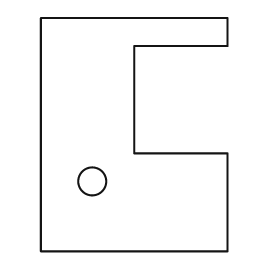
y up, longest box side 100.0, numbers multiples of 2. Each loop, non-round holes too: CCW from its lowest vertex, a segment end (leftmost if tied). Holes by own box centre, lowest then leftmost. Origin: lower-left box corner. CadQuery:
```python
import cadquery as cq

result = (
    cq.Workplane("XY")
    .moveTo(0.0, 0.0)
    .lineTo(80.0, 0.0)
    .lineTo(80.0, 42.0)
    .lineTo(40.0, 42.0)
    .lineTo(40.0, 88.0)
    .lineTo(80.0, 88.0)
    .lineTo(80.0, 100.0)
    .lineTo(0.0, 100.0)
    .close()
    .moveTo(22.0, 30.0)
    .circle(6.0)
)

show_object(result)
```